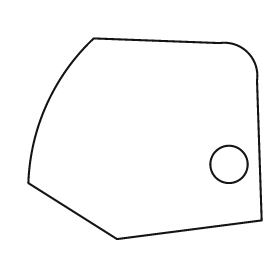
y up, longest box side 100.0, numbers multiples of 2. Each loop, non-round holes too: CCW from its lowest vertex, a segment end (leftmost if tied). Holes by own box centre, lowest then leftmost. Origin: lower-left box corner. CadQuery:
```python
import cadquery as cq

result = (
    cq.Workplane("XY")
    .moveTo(38.0, 0.0)
    .lineTo(100.0, 8.0)
    .lineTo(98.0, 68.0)
    .threePointArc((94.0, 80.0), (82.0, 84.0))
    .lineTo(28.0, 86.0)
    .threePointArc((8.0, 58.0), (0.0, 24.0))
    .close()
    .moveTo(86.0, 32.0)
    .circle(8.0)
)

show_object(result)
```